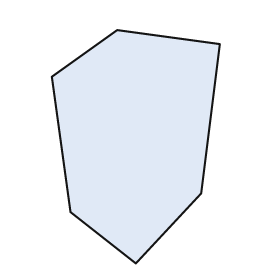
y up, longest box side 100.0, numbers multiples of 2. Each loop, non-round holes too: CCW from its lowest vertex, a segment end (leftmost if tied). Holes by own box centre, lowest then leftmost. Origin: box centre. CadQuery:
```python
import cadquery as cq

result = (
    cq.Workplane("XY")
    .moveTo(0.0, -50.0)
    .lineTo(28.0, -20.0)
    .lineTo(36.0, 44.0)
    .lineTo(-8.0, 50.0)
    .lineTo(-36.0, 30.0)
    .lineTo(-28.0, -28.0)
    .close()
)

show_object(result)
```